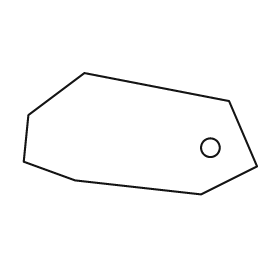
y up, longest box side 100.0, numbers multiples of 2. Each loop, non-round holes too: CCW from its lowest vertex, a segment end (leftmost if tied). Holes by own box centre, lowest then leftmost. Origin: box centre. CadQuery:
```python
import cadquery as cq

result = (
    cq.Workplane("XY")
    .moveTo(26.0, -26.0)
    .lineTo(50.0, -14.0)
    .lineTo(38.0, 14.0)
    .lineTo(-24.0, 26.0)
    .lineTo(-48.0, 8.0)
    .lineTo(-50.0, -12.0)
    .lineTo(-28.0, -20.0)
    .close()
    .moveTo(30.0, -6.0)
    .circle(4.0)
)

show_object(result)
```